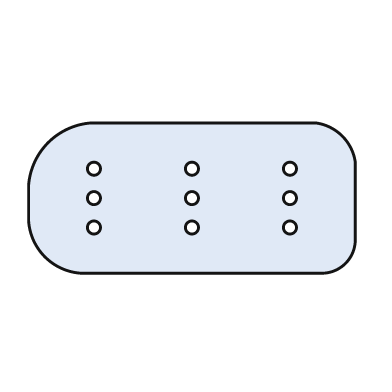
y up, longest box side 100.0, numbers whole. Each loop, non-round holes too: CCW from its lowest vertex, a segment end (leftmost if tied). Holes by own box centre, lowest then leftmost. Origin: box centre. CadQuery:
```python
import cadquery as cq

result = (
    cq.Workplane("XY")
    .moveTo(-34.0, -23.0)
    .lineTo(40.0, -23.0)
    .threePointArc((47.0, -20.0), (50.0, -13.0))
    .lineTo(50.0, 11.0)
    .threePointArc((46.0, 19.0), (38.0, 23.0))
    .lineTo(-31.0, 23.0)
    .threePointArc((-44.0, 17.0), (-50.0, 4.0))
    .lineTo(-50.0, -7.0)
    .threePointArc((-45.0, -18.0), (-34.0, -23.0))
    .close()
    .moveTo(-30.0, -9.0)
    .circle(2.0)
    .moveTo(0.0, -9.0)
    .circle(2.0)
    .moveTo(30.0, -9.0)
    .circle(2.0)
    .moveTo(-30.0, 0.0)
    .circle(2.0)
    .moveTo(0.0, 0.0)
    .circle(2.0)
    .moveTo(30.0, 0.0)
    .circle(2.0)
    .moveTo(-30.0, 9.0)
    .circle(2.0)
    .moveTo(0.0, 9.0)
    .circle(2.0)
    .moveTo(30.0, 9.0)
    .circle(2.0)
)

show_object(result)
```